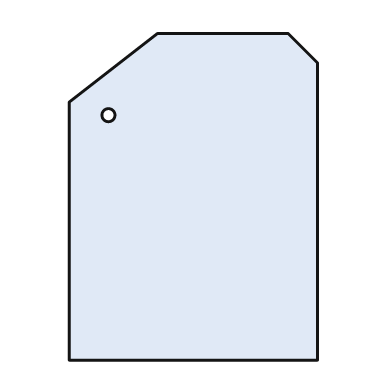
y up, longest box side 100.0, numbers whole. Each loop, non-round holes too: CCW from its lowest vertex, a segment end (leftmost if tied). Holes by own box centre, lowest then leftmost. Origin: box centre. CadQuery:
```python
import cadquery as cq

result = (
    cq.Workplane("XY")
    .moveTo(-38.0, -50.0)
    .lineTo(38.0, -50.0)
    .lineTo(38.0, 41.0)
    .lineTo(29.0, 50.0)
    .lineTo(-11.0, 50.0)
    .lineTo(-38.0, 29.0)
    .close()
    .moveTo(-26.0, 25.0)
    .circle(2.0)
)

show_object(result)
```